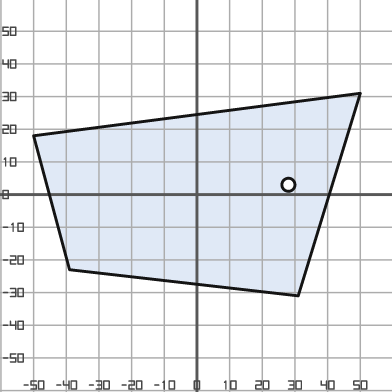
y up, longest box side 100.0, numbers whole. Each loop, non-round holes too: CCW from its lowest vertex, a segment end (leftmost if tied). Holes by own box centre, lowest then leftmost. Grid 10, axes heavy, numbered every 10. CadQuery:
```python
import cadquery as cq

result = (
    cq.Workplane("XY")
    .moveTo(31.0, -31.0)
    .lineTo(50.0, 31.0)
    .lineTo(-50.0, 18.0)
    .lineTo(-39.0, -23.0)
    .close()
    .moveTo(28.0, 3.0)
    .circle(2.0)
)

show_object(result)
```